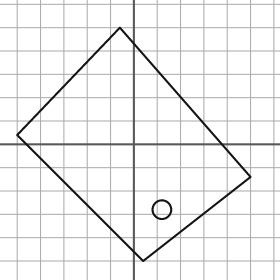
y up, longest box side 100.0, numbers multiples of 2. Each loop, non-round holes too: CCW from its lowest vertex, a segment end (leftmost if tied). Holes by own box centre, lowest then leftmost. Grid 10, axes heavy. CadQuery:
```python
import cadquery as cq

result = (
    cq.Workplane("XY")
    .moveTo(4.0, -50.0)
    .lineTo(50.0, -14.0)
    .lineTo(-6.0, 50.0)
    .lineTo(-50.0, 4.0)
    .close()
    .moveTo(12.0, -28.0)
    .circle(4.0)
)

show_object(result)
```